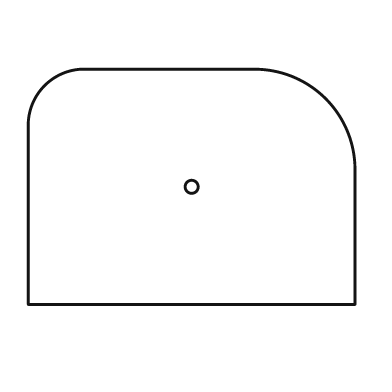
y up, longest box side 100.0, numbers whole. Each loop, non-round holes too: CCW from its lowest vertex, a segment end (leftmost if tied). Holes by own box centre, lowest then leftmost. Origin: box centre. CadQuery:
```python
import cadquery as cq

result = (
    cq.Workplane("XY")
    .moveTo(-50.0, -36.0)
    .lineTo(50.0, -36.0)
    .lineTo(50.0, 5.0)
    .threePointArc((41.0, 27.0), (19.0, 36.0))
    .lineTo(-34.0, 36.0)
    .threePointArc((-45.0, 31.0), (-50.0, 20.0))
    .close()
    .moveTo(0.0, 0.0)
    .circle(2.0)
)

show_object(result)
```